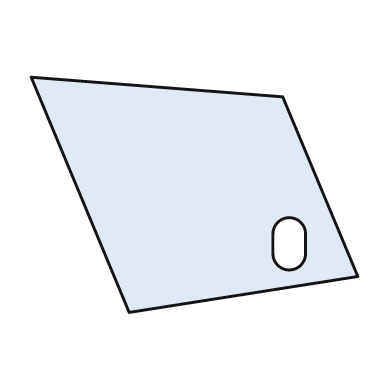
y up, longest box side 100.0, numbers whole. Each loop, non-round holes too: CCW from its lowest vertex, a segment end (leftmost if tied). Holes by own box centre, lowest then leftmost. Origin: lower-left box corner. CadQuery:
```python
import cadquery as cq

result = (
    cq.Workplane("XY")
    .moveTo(30.0, 0.0)
    .lineTo(100.0, 11.0)
    .lineTo(77.0, 66.0)
    .lineTo(0.0, 72.0)
    .close()
    .moveTo(74.0, 18.0)
    .threePointArc((79.0, 13.0), (84.0, 18.0))
    .lineTo(84.0, 24.0)
    .threePointArc((79.0, 29.0), (74.0, 24.0))
    .close()
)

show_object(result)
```